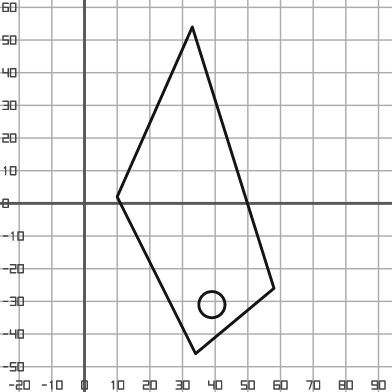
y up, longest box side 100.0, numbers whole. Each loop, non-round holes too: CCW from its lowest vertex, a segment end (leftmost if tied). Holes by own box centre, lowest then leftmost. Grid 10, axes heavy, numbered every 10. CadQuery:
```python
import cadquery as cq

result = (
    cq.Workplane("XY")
    .moveTo(34.0, -46.0)
    .lineTo(58.0, -26.0)
    .lineTo(33.0, 54.0)
    .lineTo(10.0, 2.0)
    .close()
    .moveTo(39.0, -31.0)
    .circle(4.0)
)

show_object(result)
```